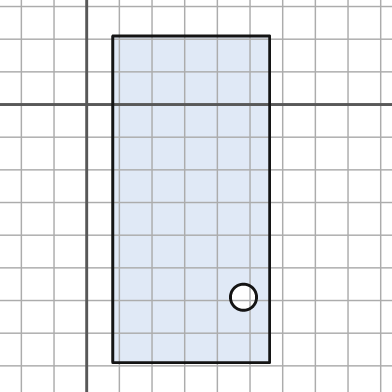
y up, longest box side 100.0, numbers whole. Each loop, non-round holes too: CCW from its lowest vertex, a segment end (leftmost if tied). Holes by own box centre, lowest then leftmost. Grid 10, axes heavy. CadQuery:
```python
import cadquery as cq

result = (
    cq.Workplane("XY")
    .moveTo(8.0, -79.0)
    .lineTo(56.0, -79.0)
    .lineTo(56.0, 21.0)
    .lineTo(8.0, 21.0)
    .close()
    .moveTo(48.0, -59.0)
    .circle(4.0)
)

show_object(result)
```